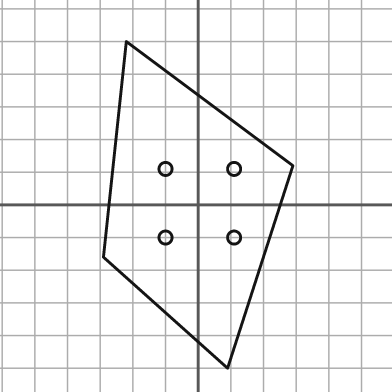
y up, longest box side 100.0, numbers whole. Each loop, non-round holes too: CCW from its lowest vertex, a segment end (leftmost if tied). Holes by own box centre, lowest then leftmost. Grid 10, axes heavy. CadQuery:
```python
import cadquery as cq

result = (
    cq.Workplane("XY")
    .moveTo(9.0, -50.0)
    .lineTo(29.0, 12.0)
    .lineTo(-22.0, 50.0)
    .lineTo(-29.0, -16.0)
    .close()
    .moveTo(-10.0, -10.0)
    .circle(2.0)
    .moveTo(11.0, -10.0)
    .circle(2.0)
    .moveTo(-10.0, 11.0)
    .circle(2.0)
    .moveTo(11.0, 11.0)
    .circle(2.0)
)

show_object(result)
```